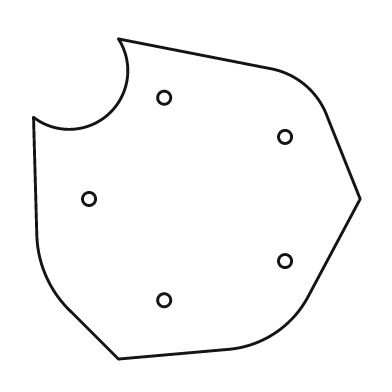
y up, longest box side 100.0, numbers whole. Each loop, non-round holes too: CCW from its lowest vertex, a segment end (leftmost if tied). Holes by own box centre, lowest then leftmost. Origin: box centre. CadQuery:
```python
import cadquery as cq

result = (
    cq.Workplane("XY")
    .moveTo(-24.0, -49.0)
    .lineTo(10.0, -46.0)
    .threePointArc((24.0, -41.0), (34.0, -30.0))
    .lineTo(50.0, 0.0)
    .lineTo(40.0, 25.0)
    .threePointArc((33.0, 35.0), (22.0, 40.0))
    .lineTo(-24.0, 49.0)
    .threePointArc((-27.0, 26.0), (-50.0, 25.0))
    .lineTo(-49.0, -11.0)
    .threePointArc((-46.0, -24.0), (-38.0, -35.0))
    .close()
    .moveTo(-10.0, -31.0)
    .circle(2.0)
    .moveTo(27.0, -19.0)
    .circle(2.0)
    .moveTo(-33.0, 0.0)
    .circle(2.0)
    .moveTo(27.0, 19.0)
    .circle(2.0)
    .moveTo(-10.0, 31.0)
    .circle(2.0)
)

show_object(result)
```